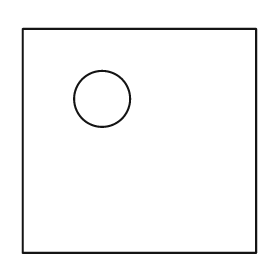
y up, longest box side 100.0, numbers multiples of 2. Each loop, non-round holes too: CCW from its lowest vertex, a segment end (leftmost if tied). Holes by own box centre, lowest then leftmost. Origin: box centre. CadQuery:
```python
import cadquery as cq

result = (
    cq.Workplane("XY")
    .moveTo(-50.0, -48.0)
    .lineTo(50.0, -48.0)
    .lineTo(50.0, 48.0)
    .lineTo(-50.0, 48.0)
    .close()
    .moveTo(-16.0, 18.0)
    .circle(12.0)
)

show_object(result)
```